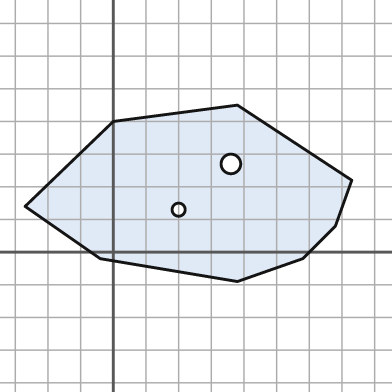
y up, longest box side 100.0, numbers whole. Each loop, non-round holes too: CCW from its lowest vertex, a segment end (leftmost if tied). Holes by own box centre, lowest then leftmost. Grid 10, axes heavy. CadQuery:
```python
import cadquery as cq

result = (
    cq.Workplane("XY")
    .moveTo(38.0, -9.0)
    .lineTo(58.0, -2.0)
    .lineTo(68.0, 8.0)
    .lineTo(73.0, 22.0)
    .lineTo(38.0, 45.0)
    .lineTo(0.0, 40.0)
    .lineTo(-27.0, 14.0)
    .lineTo(-4.0, -2.0)
    .close()
    .moveTo(20.0, 13.0)
    .circle(2.0)
    .moveTo(36.0, 27.0)
    .circle(3.0)
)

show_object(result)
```